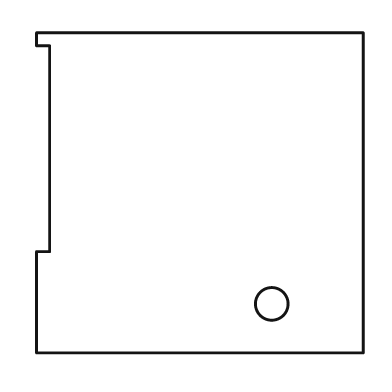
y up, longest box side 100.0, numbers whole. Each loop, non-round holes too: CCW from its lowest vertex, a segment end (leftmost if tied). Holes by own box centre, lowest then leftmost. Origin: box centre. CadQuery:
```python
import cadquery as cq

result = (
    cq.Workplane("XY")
    .moveTo(-50.0, -49.0)
    .lineTo(50.0, -49.0)
    .lineTo(50.0, 49.0)
    .lineTo(-50.0, 49.0)
    .lineTo(-50.0, 45.0)
    .lineTo(-46.0, 45.0)
    .lineTo(-46.0, -18.0)
    .lineTo(-50.0, -18.0)
    .close()
    .moveTo(22.0, -34.0)
    .circle(5.0)
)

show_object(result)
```